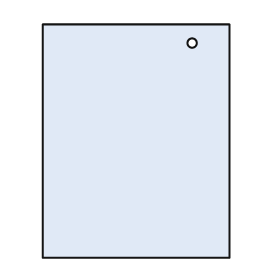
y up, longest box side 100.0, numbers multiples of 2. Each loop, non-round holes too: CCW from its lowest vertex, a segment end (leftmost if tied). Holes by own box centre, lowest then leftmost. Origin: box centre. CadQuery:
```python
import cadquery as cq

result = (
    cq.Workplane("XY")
    .moveTo(-40.0, -50.0)
    .lineTo(40.0, -50.0)
    .lineTo(40.0, 50.0)
    .lineTo(-40.0, 50.0)
    .close()
    .moveTo(24.0, 42.0)
    .circle(2.0)
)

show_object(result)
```